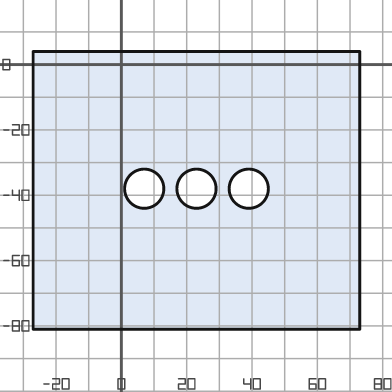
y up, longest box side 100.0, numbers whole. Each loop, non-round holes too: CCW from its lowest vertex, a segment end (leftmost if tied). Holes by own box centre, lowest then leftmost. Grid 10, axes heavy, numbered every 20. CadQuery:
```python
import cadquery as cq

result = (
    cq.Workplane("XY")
    .moveTo(-27.0, -81.0)
    .lineTo(73.0, -81.0)
    .lineTo(73.0, 4.0)
    .lineTo(-27.0, 4.0)
    .close()
    .moveTo(7.0, -38.0)
    .circle(6.0)
    .moveTo(23.0, -38.0)
    .circle(6.0)
    .moveTo(39.0, -38.0)
    .circle(6.0)
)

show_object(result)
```